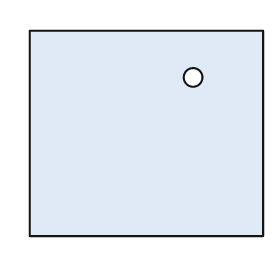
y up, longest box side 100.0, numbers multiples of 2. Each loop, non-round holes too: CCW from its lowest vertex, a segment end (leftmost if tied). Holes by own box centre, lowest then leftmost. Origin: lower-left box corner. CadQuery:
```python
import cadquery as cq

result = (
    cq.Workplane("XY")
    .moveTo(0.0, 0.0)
    .lineTo(100.0, 0.0)
    .lineTo(100.0, 88.0)
    .lineTo(0.0, 88.0)
    .close()
    .moveTo(70.0, 68.0)
    .circle(4.0)
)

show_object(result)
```